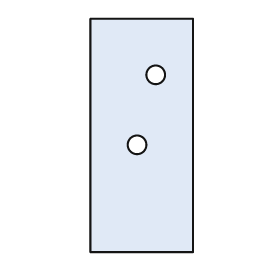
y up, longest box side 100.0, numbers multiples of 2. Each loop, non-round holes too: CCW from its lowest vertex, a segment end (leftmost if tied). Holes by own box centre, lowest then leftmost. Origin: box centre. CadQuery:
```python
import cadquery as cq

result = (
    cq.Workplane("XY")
    .moveTo(-22.0, -50.0)
    .lineTo(22.0, -50.0)
    .lineTo(22.0, 50.0)
    .lineTo(-22.0, 50.0)
    .close()
    .moveTo(-2.0, -4.0)
    .circle(4.0)
    .moveTo(6.0, 26.0)
    .circle(4.0)
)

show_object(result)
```